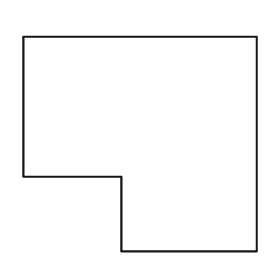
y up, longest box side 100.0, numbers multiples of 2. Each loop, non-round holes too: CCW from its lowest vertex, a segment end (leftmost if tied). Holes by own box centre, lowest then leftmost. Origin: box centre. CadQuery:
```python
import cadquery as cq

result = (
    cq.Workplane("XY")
    .moveTo(-8.0, -46.0)
    .lineTo(50.0, -46.0)
    .lineTo(50.0, 46.0)
    .lineTo(-50.0, 46.0)
    .lineTo(-50.0, -14.0)
    .lineTo(-8.0, -14.0)
    .close()
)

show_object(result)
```